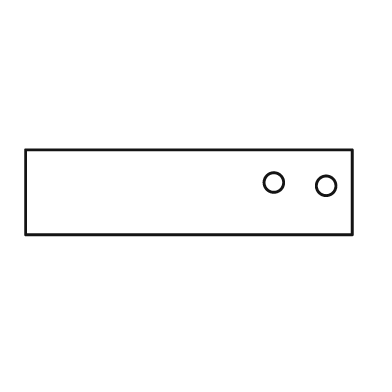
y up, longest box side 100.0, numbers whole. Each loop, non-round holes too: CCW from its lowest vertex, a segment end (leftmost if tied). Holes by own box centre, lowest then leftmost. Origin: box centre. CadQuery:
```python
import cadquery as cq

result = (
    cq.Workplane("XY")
    .moveTo(-50.0, -13.0)
    .lineTo(50.0, -13.0)
    .lineTo(50.0, 13.0)
    .lineTo(-50.0, 13.0)
    .close()
    .moveTo(42.0, 2.0)
    .circle(3.0)
    .moveTo(26.0, 3.0)
    .circle(3.0)
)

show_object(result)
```